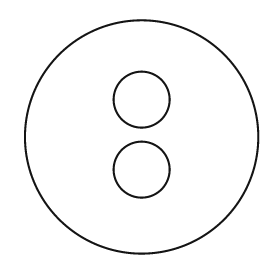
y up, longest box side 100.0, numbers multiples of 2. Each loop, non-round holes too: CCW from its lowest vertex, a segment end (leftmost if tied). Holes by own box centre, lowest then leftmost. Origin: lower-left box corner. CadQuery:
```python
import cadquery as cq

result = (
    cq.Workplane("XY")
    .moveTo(50.0, 50.0)
    .circle(50.0)
    .moveTo(50.0, 36.0)
    .circle(12.0)
    .moveTo(50.0, 66.0)
    .circle(12.0)
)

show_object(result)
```